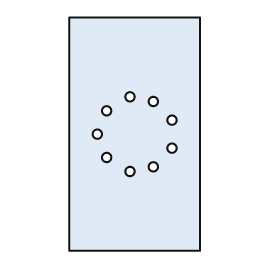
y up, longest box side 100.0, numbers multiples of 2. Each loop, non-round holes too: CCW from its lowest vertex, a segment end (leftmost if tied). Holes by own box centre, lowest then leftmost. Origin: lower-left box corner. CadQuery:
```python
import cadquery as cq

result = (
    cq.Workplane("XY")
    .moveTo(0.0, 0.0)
    .lineTo(56.0, 0.0)
    .lineTo(56.0, 100.0)
    .lineTo(0.0, 100.0)
    .close()
    .moveTo(26.0, 34.0)
    .circle(2.0)
    .moveTo(36.0, 36.0)
    .circle(2.0)
    .moveTo(16.0, 40.0)
    .circle(2.0)
    .moveTo(44.0, 44.0)
    .circle(2.0)
    .moveTo(12.0, 50.0)
    .circle(2.0)
    .moveTo(44.0, 56.0)
    .circle(2.0)
    .moveTo(16.0, 60.0)
    .circle(2.0)
    .moveTo(36.0, 64.0)
    .circle(2.0)
    .moveTo(26.0, 66.0)
    .circle(2.0)
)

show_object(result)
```